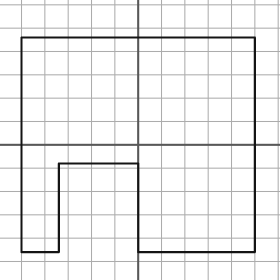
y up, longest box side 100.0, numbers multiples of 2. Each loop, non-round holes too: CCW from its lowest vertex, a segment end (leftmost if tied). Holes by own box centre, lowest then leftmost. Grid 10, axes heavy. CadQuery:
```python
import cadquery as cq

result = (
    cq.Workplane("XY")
    .moveTo(-50.0, -46.0)
    .lineTo(-34.0, -46.0)
    .lineTo(-34.0, -8.0)
    .lineTo(0.0, -8.0)
    .lineTo(0.0, -46.0)
    .lineTo(50.0, -46.0)
    .lineTo(50.0, 46.0)
    .lineTo(-50.0, 46.0)
    .close()
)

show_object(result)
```